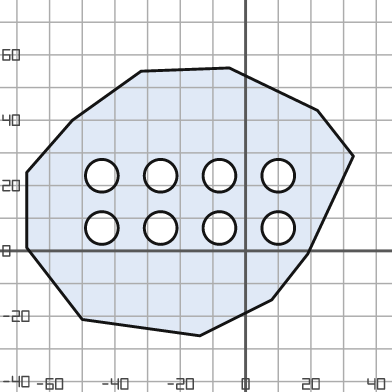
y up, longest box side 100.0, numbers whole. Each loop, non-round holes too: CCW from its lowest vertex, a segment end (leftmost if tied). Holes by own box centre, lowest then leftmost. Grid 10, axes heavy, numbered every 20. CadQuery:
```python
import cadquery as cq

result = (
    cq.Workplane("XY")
    .moveTo(-14.0, -26.0)
    .lineTo(8.0, -15.0)
    .lineTo(19.0, -1.0)
    .lineTo(33.0, 29.0)
    .lineTo(22.0, 43.0)
    .lineTo(-5.0, 56.0)
    .lineTo(-32.0, 55.0)
    .lineTo(-53.0, 40.0)
    .lineTo(-67.0, 24.0)
    .lineTo(-67.0, 1.0)
    .lineTo(-50.0, -21.0)
    .close()
    .moveTo(-44.0, 7.0)
    .circle(5.0)
    .moveTo(-26.0, 7.0)
    .circle(5.0)
    .moveTo(-8.0, 7.0)
    .circle(5.0)
    .moveTo(10.0, 7.0)
    .circle(5.0)
    .moveTo(-44.0, 23.0)
    .circle(5.0)
    .moveTo(-26.0, 23.0)
    .circle(5.0)
    .moveTo(-8.0, 23.0)
    .circle(5.0)
    .moveTo(10.0, 23.0)
    .circle(5.0)
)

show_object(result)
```